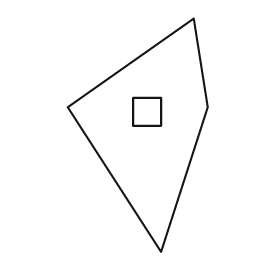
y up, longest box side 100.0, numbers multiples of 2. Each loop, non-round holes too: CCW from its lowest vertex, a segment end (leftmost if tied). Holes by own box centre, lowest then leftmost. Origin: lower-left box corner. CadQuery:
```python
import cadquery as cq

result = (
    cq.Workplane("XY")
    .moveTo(40.0, 0.0)
    .lineTo(60.0, 62.0)
    .lineTo(54.0, 100.0)
    .lineTo(0.0, 62.0)
    .close()
    .moveTo(28.0, 54.0)
    .lineTo(40.0, 54.0)
    .lineTo(40.0, 66.0)
    .lineTo(28.0, 66.0)
    .close()
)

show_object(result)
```